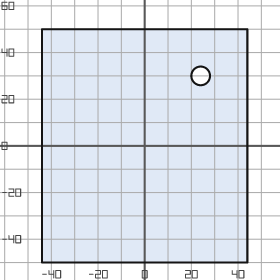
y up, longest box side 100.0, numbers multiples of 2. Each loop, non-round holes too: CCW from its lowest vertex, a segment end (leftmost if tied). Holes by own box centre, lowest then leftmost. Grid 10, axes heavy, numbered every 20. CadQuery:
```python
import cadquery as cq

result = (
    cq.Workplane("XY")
    .moveTo(-44.0, -50.0)
    .lineTo(44.0, -50.0)
    .lineTo(44.0, 50.0)
    .lineTo(-44.0, 50.0)
    .close()
    .moveTo(24.0, 30.0)
    .circle(4.0)
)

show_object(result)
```